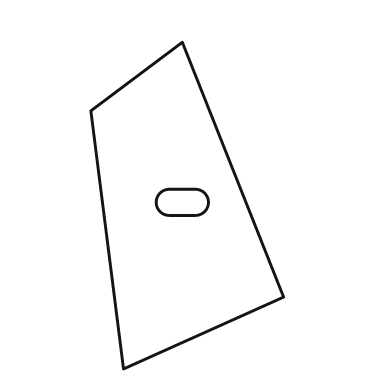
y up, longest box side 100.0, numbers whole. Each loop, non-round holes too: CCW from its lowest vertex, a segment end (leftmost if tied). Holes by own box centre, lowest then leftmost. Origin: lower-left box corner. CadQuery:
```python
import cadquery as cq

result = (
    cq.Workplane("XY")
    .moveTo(10.0, 0.0)
    .lineTo(59.0, 22.0)
    .lineTo(28.0, 100.0)
    .lineTo(0.0, 79.0)
    .close()
    .moveTo(24.0, 47.0)
    .lineTo(32.0, 47.0)
    .threePointArc((36.0, 51.0), (32.0, 55.0))
    .lineTo(24.0, 55.0)
    .threePointArc((20.0, 51.0), (24.0, 47.0))
    .close()
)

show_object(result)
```